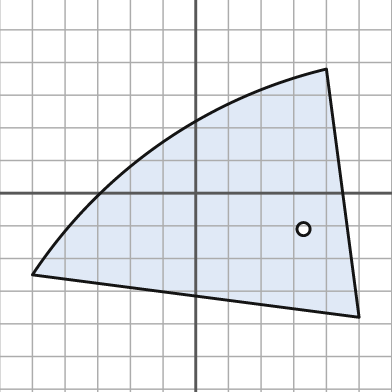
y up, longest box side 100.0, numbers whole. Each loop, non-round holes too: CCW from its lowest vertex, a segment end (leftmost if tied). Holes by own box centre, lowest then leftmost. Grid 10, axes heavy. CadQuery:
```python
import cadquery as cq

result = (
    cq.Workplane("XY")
    .moveTo(50.0, -38.0)
    .lineTo(40.0, 38.0)
    .threePointArc((-11.0, 15.0), (-50.0, -25.0))
    .close()
    .moveTo(33.0, -11.0)
    .circle(2.0)
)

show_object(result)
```